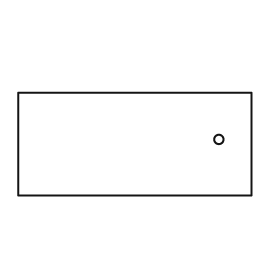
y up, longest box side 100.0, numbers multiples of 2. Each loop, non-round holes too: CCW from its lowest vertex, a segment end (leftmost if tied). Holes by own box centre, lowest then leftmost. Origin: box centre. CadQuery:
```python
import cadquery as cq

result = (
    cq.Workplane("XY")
    .moveTo(-50.0, -22.0)
    .lineTo(50.0, -22.0)
    .lineTo(50.0, 22.0)
    .lineTo(-50.0, 22.0)
    .close()
    .moveTo(36.0, 2.0)
    .circle(2.0)
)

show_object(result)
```